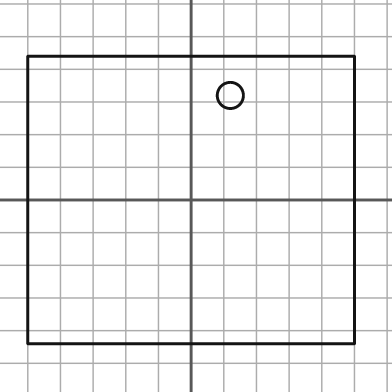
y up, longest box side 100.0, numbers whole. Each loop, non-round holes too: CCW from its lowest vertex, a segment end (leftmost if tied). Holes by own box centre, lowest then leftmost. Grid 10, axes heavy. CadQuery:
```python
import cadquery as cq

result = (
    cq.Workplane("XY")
    .moveTo(-50.0, -44.0)
    .lineTo(50.0, -44.0)
    .lineTo(50.0, 44.0)
    .lineTo(-50.0, 44.0)
    .close()
    .moveTo(12.0, 32.0)
    .circle(4.0)
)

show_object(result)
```